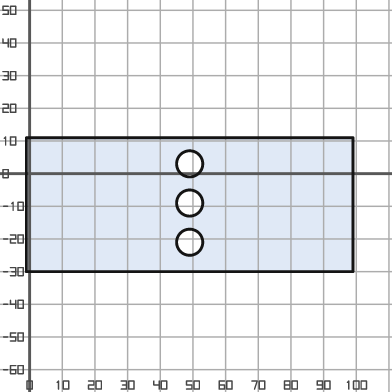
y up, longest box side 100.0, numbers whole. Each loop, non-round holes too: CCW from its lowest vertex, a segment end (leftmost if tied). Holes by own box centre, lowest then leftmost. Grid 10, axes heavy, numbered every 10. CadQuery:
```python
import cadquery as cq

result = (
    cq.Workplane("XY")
    .moveTo(-1.0, -30.0)
    .lineTo(99.0, -30.0)
    .lineTo(99.0, 11.0)
    .lineTo(-1.0, 11.0)
    .close()
    .moveTo(49.0, -21.0)
    .circle(4.0)
    .moveTo(49.0, -9.0)
    .circle(4.0)
    .moveTo(49.0, 3.0)
    .circle(4.0)
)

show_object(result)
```